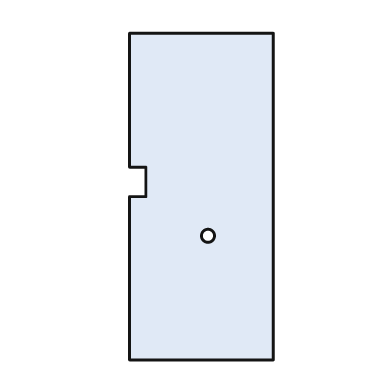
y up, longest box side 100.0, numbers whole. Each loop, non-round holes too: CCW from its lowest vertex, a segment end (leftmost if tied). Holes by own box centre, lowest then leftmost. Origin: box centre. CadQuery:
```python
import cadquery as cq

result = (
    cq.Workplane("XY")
    .moveTo(-22.0, -50.0)
    .lineTo(22.0, -50.0)
    .lineTo(22.0, 50.0)
    .lineTo(-22.0, 50.0)
    .lineTo(-22.0, 9.0)
    .lineTo(-17.0, 9.0)
    .lineTo(-17.0, 0.0)
    .lineTo(-22.0, 0.0)
    .close()
    .moveTo(2.0, -12.0)
    .circle(2.0)
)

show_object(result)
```